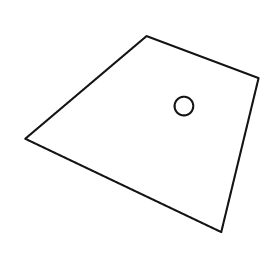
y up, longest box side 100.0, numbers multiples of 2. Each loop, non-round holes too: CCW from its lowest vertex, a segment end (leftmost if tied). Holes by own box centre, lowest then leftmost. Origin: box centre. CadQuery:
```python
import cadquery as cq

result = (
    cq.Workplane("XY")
    .moveTo(34.0, -42.0)
    .lineTo(50.0, 24.0)
    .lineTo(2.0, 42.0)
    .lineTo(-50.0, -2.0)
    .close()
    .moveTo(18.0, 12.0)
    .circle(4.0)
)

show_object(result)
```